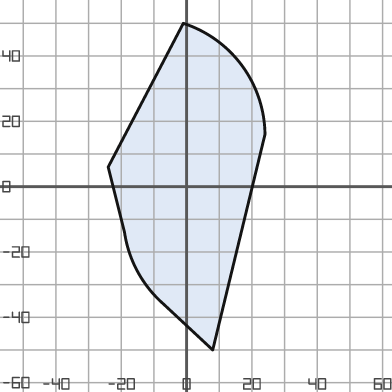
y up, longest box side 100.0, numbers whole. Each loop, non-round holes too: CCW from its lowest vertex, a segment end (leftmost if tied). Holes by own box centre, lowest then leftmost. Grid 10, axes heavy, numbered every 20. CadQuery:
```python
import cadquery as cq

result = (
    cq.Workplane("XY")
    .moveTo(8.0, -50.0)
    .lineTo(24.0, 16.0)
    .threePointArc((17.0, 37.0), (-1.0, 50.0))
    .lineTo(-24.0, 6.0)
    .lineTo(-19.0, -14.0)
    .threePointArc((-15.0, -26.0), (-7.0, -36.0))
    .close()
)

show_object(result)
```